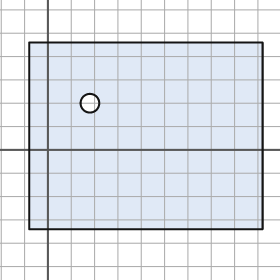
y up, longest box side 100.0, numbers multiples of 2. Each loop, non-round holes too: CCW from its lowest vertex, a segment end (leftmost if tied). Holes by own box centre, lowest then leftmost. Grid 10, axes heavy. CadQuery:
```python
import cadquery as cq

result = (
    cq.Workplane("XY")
    .moveTo(-8.0, -34.0)
    .lineTo(92.0, -34.0)
    .lineTo(92.0, 46.0)
    .lineTo(-8.0, 46.0)
    .close()
    .moveTo(18.0, 20.0)
    .circle(4.0)
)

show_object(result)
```